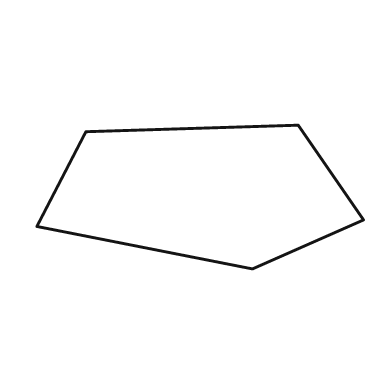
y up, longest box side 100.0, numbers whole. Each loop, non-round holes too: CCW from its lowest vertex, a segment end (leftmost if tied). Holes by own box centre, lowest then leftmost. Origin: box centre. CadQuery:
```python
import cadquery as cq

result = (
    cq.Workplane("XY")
    .moveTo(16.0, -22.0)
    .lineTo(50.0, -7.0)
    .lineTo(30.0, 22.0)
    .lineTo(-35.0, 20.0)
    .lineTo(-50.0, -9.0)
    .close()
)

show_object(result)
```